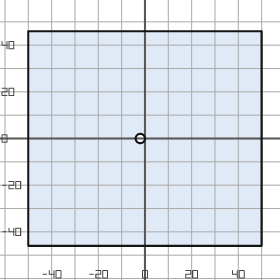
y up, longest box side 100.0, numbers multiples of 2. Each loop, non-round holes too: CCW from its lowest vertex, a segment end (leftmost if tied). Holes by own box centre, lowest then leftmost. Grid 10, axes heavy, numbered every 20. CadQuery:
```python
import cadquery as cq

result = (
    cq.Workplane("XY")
    .moveTo(-50.0, -46.0)
    .lineTo(50.0, -46.0)
    .lineTo(50.0, 46.0)
    .lineTo(-50.0, 46.0)
    .close()
    .moveTo(-2.0, 0.0)
    .circle(2.0)
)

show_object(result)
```